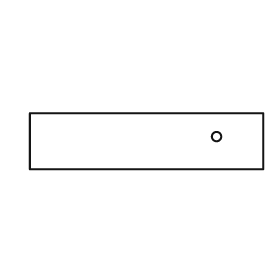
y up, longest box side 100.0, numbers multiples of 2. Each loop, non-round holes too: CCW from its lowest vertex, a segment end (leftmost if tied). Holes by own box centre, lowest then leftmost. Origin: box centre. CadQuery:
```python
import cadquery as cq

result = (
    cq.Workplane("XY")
    .moveTo(-50.0, -12.0)
    .lineTo(50.0, -12.0)
    .lineTo(50.0, 12.0)
    .lineTo(-50.0, 12.0)
    .close()
    .moveTo(30.0, 2.0)
    .circle(2.0)
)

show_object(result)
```